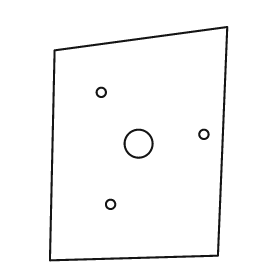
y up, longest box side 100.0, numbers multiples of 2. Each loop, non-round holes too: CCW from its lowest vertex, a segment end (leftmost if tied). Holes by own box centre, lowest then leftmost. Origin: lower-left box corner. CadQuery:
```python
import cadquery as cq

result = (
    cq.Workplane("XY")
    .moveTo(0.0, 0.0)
    .lineTo(72.0, 2.0)
    .lineTo(76.0, 100.0)
    .lineTo(2.0, 90.0)
    .close()
    .moveTo(26.0, 24.0)
    .circle(2.0)
    .moveTo(38.0, 50.0)
    .circle(6.0)
    .moveTo(66.0, 54.0)
    .circle(2.0)
    .moveTo(22.0, 72.0)
    .circle(2.0)
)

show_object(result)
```